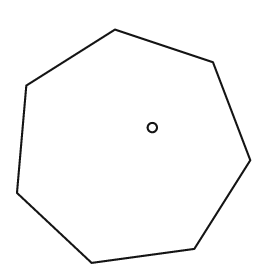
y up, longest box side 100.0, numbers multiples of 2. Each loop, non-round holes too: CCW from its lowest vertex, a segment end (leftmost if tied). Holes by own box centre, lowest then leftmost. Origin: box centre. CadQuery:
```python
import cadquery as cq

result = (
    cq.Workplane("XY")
    .moveTo(-18.0, -50.0)
    .lineTo(26.0, -44.0)
    .lineTo(50.0, -6.0)
    .lineTo(34.0, 36.0)
    .lineTo(-8.0, 50.0)
    .lineTo(-46.0, 26.0)
    .lineTo(-50.0, -20.0)
    .close()
    .moveTo(8.0, 8.0)
    .circle(2.0)
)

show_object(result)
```